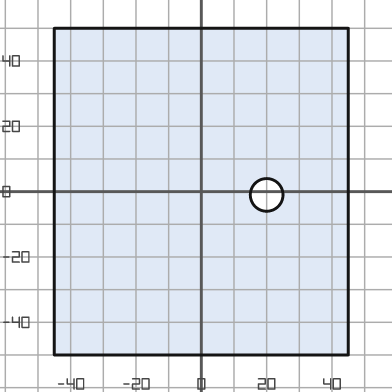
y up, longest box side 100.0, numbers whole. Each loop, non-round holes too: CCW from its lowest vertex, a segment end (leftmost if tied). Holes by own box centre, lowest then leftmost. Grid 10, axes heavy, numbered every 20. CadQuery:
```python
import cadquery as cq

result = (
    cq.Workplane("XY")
    .moveTo(-45.0, -50.0)
    .lineTo(45.0, -50.0)
    .lineTo(45.0, 50.0)
    .lineTo(-45.0, 50.0)
    .close()
    .moveTo(20.0, -1.0)
    .circle(5.0)
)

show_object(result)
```